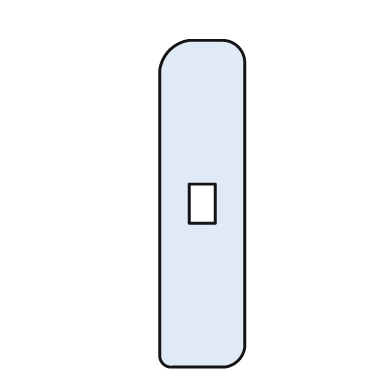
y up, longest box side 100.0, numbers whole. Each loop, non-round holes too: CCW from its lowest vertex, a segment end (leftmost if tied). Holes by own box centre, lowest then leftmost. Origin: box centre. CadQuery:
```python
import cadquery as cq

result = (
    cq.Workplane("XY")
    .moveTo(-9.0, -50.0)
    .lineTo(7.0, -50.0)
    .threePointArc((11.0, -48.0), (13.0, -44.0))
    .lineTo(13.0, 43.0)
    .threePointArc((11.0, 48.0), (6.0, 50.0))
    .lineTo(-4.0, 50.0)
    .threePointArc((-10.0, 47.0), (-13.0, 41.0))
    .lineTo(-13.0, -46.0)
    .threePointArc((-12.0, -49.0), (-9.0, -50.0))
    .close()
    .moveTo(-4.0, -6.0)
    .lineTo(4.0, -6.0)
    .lineTo(4.0, 6.0)
    .lineTo(-4.0, 6.0)
    .close()
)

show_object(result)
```